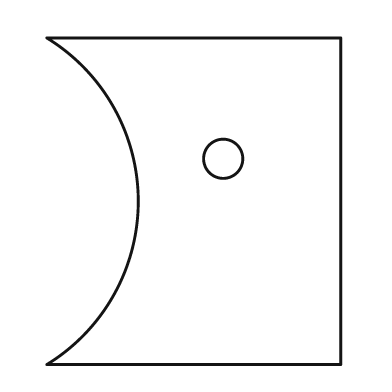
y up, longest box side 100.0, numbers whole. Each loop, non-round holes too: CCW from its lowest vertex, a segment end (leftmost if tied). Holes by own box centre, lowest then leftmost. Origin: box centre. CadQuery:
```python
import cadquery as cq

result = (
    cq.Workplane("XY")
    .moveTo(-45.0, -50.0)
    .lineTo(45.0, -50.0)
    .lineTo(45.0, 50.0)
    .lineTo(-45.0, 50.0)
    .threePointArc((-17.0, 0.0), (-45.0, -50.0))
    .close()
    .moveTo(9.0, 13.0)
    .circle(6.0)
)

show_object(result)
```